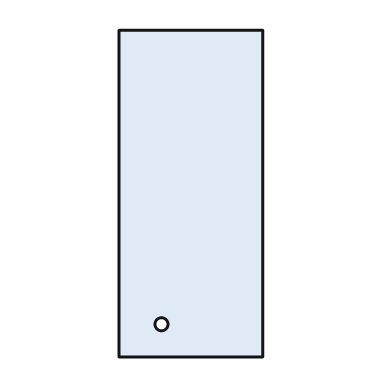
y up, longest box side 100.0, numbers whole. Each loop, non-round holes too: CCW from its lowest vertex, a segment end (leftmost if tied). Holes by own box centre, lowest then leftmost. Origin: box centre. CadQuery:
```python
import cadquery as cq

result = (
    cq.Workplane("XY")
    .moveTo(-22.0, -50.0)
    .lineTo(22.0, -50.0)
    .lineTo(22.0, 50.0)
    .lineTo(-22.0, 50.0)
    .close()
    .moveTo(-9.0, -40.0)
    .circle(2.0)
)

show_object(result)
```